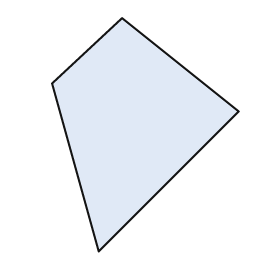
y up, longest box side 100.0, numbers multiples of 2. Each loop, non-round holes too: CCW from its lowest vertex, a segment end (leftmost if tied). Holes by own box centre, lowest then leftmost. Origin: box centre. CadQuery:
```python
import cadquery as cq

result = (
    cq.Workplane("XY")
    .moveTo(-20.0, -50.0)
    .lineTo(40.0, 10.0)
    .lineTo(-10.0, 50.0)
    .lineTo(-40.0, 22.0)
    .close()
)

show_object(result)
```